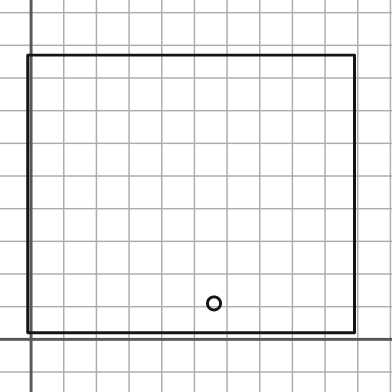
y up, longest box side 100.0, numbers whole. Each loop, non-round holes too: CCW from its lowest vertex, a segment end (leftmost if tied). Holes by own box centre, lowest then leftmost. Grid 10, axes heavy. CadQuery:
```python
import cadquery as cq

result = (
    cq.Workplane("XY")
    .moveTo(-1.0, 2.0)
    .lineTo(99.0, 2.0)
    .lineTo(99.0, 87.0)
    .lineTo(-1.0, 87.0)
    .close()
    .moveTo(56.0, 11.0)
    .circle(2.0)
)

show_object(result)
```